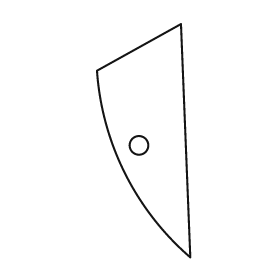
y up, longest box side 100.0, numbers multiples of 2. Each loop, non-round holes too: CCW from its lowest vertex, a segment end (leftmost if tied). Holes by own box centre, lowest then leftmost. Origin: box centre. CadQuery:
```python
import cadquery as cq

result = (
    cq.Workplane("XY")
    .moveTo(20.0, -50.0)
    .lineTo(16.0, 50.0)
    .lineTo(-20.0, 30.0)
    .threePointArc((-8.0, -14.0), (20.0, -50.0))
    .close()
    .moveTo(-2.0, -2.0)
    .circle(4.0)
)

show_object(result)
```